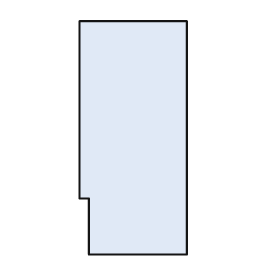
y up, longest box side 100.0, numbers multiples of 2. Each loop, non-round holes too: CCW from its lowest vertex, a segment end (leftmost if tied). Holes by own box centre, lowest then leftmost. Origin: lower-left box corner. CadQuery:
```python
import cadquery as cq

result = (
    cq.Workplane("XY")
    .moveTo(4.0, 0.0)
    .lineTo(46.0, 0.0)
    .lineTo(46.0, 100.0)
    .lineTo(0.0, 100.0)
    .lineTo(0.0, 24.0)
    .lineTo(4.0, 24.0)
    .close()
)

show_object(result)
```